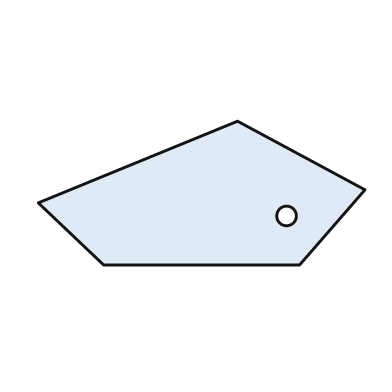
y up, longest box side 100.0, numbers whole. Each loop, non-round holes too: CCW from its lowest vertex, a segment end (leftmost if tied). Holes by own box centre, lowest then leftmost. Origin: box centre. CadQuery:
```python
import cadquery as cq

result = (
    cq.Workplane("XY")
    .moveTo(-30.0, -22.0)
    .lineTo(30.0, -22.0)
    .lineTo(50.0, 1.0)
    .lineTo(11.0, 22.0)
    .lineTo(-50.0, -3.0)
    .close()
    .moveTo(26.0, -7.0)
    .circle(3.0)
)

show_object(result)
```